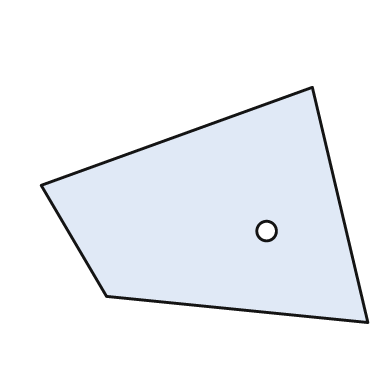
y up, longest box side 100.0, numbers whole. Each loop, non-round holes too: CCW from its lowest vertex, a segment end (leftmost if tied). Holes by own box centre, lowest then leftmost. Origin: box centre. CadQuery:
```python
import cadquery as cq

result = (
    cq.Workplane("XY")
    .moveTo(50.0, -36.0)
    .lineTo(33.0, 36.0)
    .lineTo(-50.0, 6.0)
    .lineTo(-30.0, -28.0)
    .close()
    .moveTo(19.0, -8.0)
    .circle(3.0)
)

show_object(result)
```